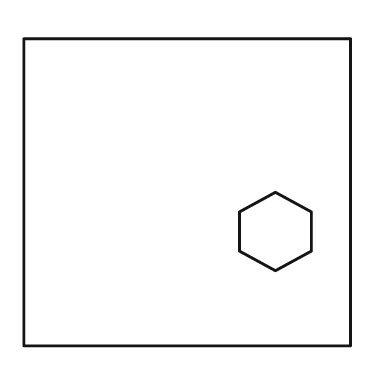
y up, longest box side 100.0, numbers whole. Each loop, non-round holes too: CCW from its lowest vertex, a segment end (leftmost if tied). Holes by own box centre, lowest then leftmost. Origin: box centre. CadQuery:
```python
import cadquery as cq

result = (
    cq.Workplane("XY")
    .moveTo(-50.0, -47.0)
    .lineTo(50.0, -47.0)
    .lineTo(50.0, 47.0)
    .lineTo(-50.0, 47.0)
    .close()
    .moveTo(27.0, -24.0)
    .lineTo(38.0, -18.0)
    .lineTo(38.0, -6.0)
    .lineTo(27.0, 0.0)
    .lineTo(16.0, -6.0)
    .lineTo(16.0, -18.0)
    .close()
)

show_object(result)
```